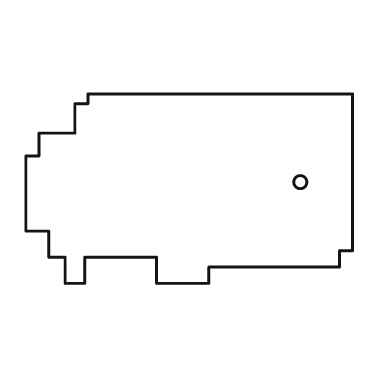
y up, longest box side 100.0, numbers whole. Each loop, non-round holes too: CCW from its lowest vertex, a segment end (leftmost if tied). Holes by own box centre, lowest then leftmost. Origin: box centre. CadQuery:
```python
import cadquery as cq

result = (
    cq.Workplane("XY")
    .moveTo(-38.0, -29.0)
    .lineTo(-32.0, -29.0)
    .lineTo(-32.0, -21.0)
    .lineTo(-10.0, -21.0)
    .lineTo(-10.0, -29.0)
    .lineTo(6.0, -29.0)
    .lineTo(6.0, -24.0)
    .lineTo(46.0, -24.0)
    .lineTo(46.0, -19.0)
    .lineTo(50.0, -19.0)
    .lineTo(50.0, 29.0)
    .lineTo(-31.0, 29.0)
    .lineTo(-31.0, 26.0)
    .lineTo(-35.0, 26.0)
    .lineTo(-35.0, 17.0)
    .lineTo(-46.0, 17.0)
    .lineTo(-46.0, 10.0)
    .lineTo(-50.0, 10.0)
    .lineTo(-50.0, -13.0)
    .lineTo(-43.0, -13.0)
    .lineTo(-43.0, -21.0)
    .lineTo(-38.0, -21.0)
    .close()
    .moveTo(34.0, 2.0)
    .circle(2.0)
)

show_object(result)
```